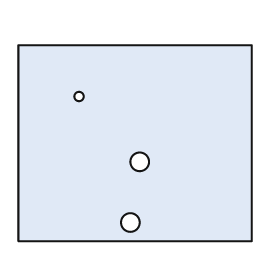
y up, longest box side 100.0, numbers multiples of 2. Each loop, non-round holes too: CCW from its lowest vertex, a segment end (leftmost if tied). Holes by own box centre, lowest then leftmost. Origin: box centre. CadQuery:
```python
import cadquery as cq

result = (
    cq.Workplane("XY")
    .moveTo(-50.0, -42.0)
    .lineTo(50.0, -42.0)
    .lineTo(50.0, 42.0)
    .lineTo(-50.0, 42.0)
    .close()
    .moveTo(-2.0, -34.0)
    .circle(4.0)
    .moveTo(2.0, -8.0)
    .circle(4.0)
    .moveTo(-24.0, 20.0)
    .circle(2.0)
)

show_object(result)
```